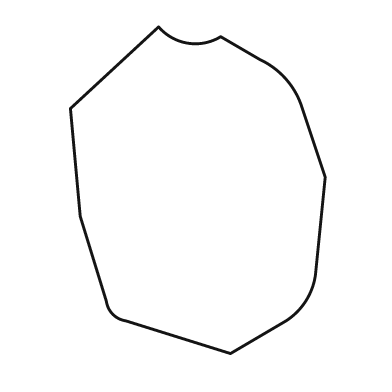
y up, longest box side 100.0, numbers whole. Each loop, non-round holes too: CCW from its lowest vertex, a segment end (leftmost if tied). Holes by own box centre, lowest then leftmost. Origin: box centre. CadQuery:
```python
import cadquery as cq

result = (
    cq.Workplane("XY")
    .moveTo(10.0, -50.0)
    .lineTo(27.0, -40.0)
    .threePointArc((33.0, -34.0), (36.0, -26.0))
    .lineTo(39.0, 4.0)
    .lineTo(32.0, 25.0)
    .threePointArc((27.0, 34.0), (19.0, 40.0))
    .lineTo(7.0, 47.0)
    .threePointArc((-3.0, 45.0), (-12.0, 50.0))
    .lineTo(-39.0, 25.0)
    .lineTo(-36.0, -8.0)
    .lineTo(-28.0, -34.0)
    .threePointArc((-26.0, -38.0), (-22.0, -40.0))
    .close()
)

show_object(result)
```